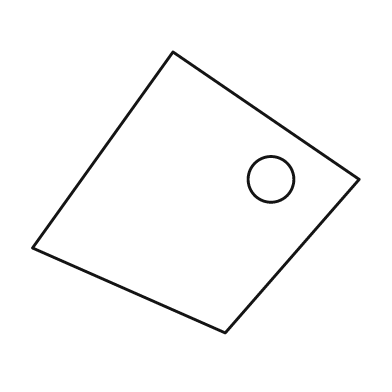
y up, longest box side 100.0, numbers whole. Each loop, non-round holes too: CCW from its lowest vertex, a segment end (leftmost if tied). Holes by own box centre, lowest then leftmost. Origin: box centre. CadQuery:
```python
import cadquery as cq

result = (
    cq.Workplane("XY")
    .moveTo(9.0, -43.0)
    .lineTo(50.0, 4.0)
    .lineTo(-7.0, 43.0)
    .lineTo(-50.0, -17.0)
    .close()
    .moveTo(23.0, 4.0)
    .circle(7.0)
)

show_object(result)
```